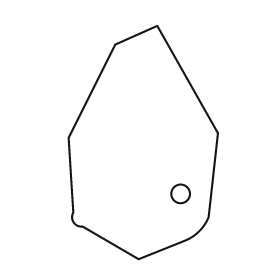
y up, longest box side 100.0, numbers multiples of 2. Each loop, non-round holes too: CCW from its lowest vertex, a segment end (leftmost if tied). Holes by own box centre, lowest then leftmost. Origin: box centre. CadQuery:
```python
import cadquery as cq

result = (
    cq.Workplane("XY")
    .moveTo(-2.0, -50.0)
    .lineTo(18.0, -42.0)
    .threePointArc((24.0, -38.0), (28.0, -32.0))
    .lineTo(32.0, 4.0)
    .lineTo(6.0, 50.0)
    .lineTo(-12.0, 42.0)
    .lineTo(-32.0, 2.0)
    .lineTo(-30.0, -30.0)
    .threePointArc((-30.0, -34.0), (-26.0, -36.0))
    .close()
    .moveTo(16.0, -22.0)
    .circle(4.0)
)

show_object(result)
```